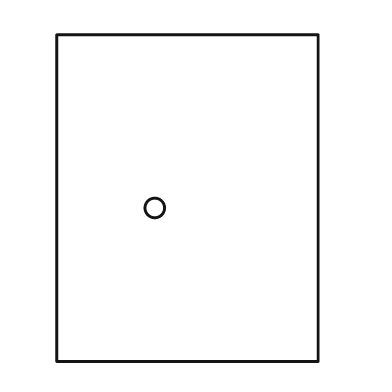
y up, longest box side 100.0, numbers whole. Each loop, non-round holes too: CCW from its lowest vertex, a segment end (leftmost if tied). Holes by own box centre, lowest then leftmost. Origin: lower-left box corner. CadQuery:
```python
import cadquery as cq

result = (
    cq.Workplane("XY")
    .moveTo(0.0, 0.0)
    .lineTo(80.0, 0.0)
    .lineTo(80.0, 100.0)
    .lineTo(0.0, 100.0)
    .close()
    .moveTo(30.0, 47.0)
    .circle(3.0)
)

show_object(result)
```